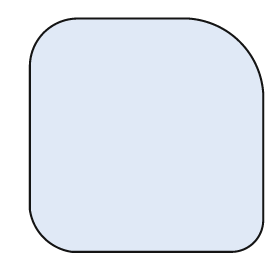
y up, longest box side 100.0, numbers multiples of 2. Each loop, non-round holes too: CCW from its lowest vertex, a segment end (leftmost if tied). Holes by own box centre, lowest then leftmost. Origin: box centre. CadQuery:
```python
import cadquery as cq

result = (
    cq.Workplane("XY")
    .moveTo(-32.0, -50.0)
    .lineTo(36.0, -50.0)
    .threePointArc((46.0, -46.0), (50.0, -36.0))
    .lineTo(50.0, 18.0)
    .threePointArc((40.0, 40.0), (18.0, 50.0))
    .lineTo(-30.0, 50.0)
    .threePointArc((-44.0, 44.0), (-50.0, 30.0))
    .lineTo(-50.0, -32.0)
    .threePointArc((-44.0, -44.0), (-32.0, -50.0))
    .close()
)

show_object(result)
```